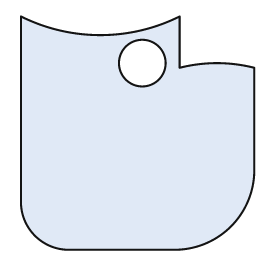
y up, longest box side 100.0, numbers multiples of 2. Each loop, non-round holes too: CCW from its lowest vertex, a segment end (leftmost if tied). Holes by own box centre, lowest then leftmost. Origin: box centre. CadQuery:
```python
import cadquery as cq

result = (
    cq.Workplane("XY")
    .moveTo(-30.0, -50.0)
    .lineTo(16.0, -50.0)
    .threePointArc((40.0, -40.0), (50.0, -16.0))
    .lineTo(50.0, 28.0)
    .threePointArc((34.0, 30.0), (18.0, 28.0))
    .lineTo(18.0, 50.0)
    .threePointArc((-16.0, 42.0), (-50.0, 50.0))
    .lineTo(-50.0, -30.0)
    .threePointArc((-44.0, -44.0), (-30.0, -50.0))
    .close()
    .moveTo(2.0, 30.0)
    .circle(10.0)
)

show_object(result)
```